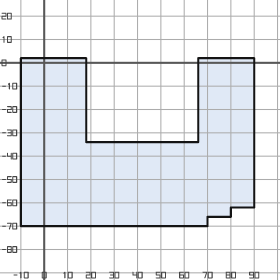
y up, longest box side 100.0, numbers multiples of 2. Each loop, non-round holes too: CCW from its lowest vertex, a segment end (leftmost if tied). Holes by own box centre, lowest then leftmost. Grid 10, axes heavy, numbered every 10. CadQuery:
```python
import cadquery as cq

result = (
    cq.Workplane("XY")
    .moveTo(-10.0, -70.0)
    .lineTo(70.0, -70.0)
    .lineTo(70.0, -66.0)
    .lineTo(80.0, -66.0)
    .lineTo(80.0, -62.0)
    .lineTo(90.0, -62.0)
    .lineTo(90.0, 2.0)
    .lineTo(66.0, 2.0)
    .lineTo(66.0, -34.0)
    .lineTo(18.0, -34.0)
    .lineTo(18.0, 2.0)
    .lineTo(-10.0, 2.0)
    .close()
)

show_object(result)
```